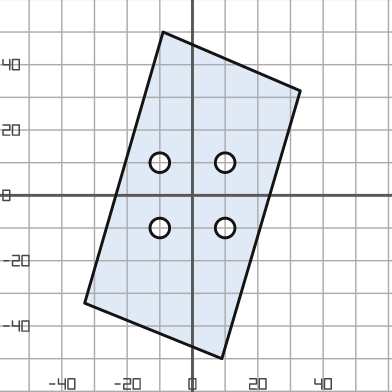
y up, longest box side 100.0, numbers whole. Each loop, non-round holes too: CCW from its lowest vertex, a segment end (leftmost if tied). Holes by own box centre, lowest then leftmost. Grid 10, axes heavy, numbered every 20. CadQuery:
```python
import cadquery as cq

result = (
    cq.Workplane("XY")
    .moveTo(9.0, -50.0)
    .lineTo(33.0, 32.0)
    .lineTo(-9.0, 50.0)
    .lineTo(-33.0, -33.0)
    .close()
    .moveTo(-10.0, -10.0)
    .circle(3.0)
    .moveTo(10.0, -10.0)
    .circle(3.0)
    .moveTo(-10.0, 10.0)
    .circle(3.0)
    .moveTo(10.0, 10.0)
    .circle(3.0)
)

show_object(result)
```